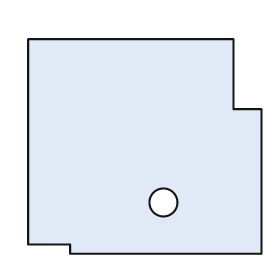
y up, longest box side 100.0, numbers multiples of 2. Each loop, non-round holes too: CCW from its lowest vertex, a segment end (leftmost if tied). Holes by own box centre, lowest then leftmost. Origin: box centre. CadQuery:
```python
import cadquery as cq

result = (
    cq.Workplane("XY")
    .moveTo(-32.0, -46.0)
    .lineTo(50.0, -46.0)
    .lineTo(50.0, 16.0)
    .lineTo(38.0, 16.0)
    .lineTo(38.0, 46.0)
    .lineTo(-50.0, 46.0)
    .lineTo(-50.0, -42.0)
    .lineTo(-32.0, -42.0)
    .close()
    .moveTo(8.0, -24.0)
    .circle(6.0)
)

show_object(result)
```